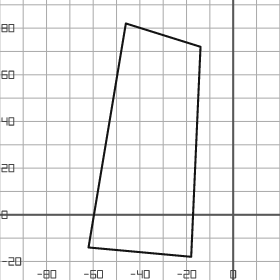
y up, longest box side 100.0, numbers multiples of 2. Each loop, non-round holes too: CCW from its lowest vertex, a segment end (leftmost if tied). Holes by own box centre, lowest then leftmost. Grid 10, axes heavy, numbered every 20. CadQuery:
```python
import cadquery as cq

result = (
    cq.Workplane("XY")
    .moveTo(-18.0, -18.0)
    .lineTo(-14.0, 72.0)
    .lineTo(-46.0, 82.0)
    .lineTo(-62.0, -14.0)
    .close()
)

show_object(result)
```